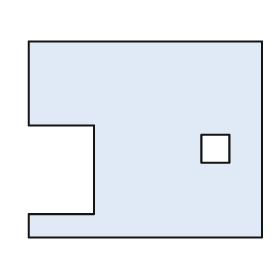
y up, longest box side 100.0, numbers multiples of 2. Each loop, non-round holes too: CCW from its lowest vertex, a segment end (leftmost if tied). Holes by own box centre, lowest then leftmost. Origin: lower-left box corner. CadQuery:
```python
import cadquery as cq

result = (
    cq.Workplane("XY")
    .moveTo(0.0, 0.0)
    .lineTo(100.0, 0.0)
    .lineTo(100.0, 84.0)
    .lineTo(0.0, 84.0)
    .lineTo(0.0, 48.0)
    .lineTo(28.0, 48.0)
    .lineTo(28.0, 10.0)
    .lineTo(0.0, 10.0)
    .close()
    .moveTo(74.0, 32.0)
    .lineTo(86.0, 32.0)
    .lineTo(86.0, 44.0)
    .lineTo(74.0, 44.0)
    .close()
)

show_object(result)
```